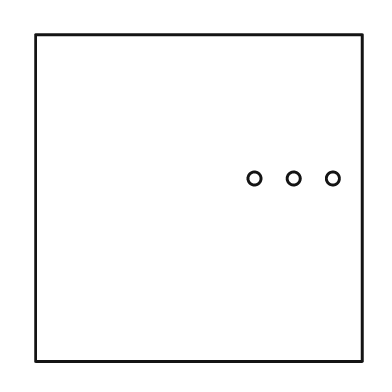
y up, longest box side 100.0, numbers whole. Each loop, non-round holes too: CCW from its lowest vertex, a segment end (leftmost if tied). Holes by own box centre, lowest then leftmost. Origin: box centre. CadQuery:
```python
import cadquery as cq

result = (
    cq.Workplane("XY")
    .moveTo(-50.0, -50.0)
    .lineTo(50.0, -50.0)
    .lineTo(50.0, 50.0)
    .lineTo(-50.0, 50.0)
    .close()
    .moveTo(17.0, 6.0)
    .circle(2.0)
    .moveTo(29.0, 6.0)
    .circle(2.0)
    .moveTo(41.0, 6.0)
    .circle(2.0)
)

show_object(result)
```